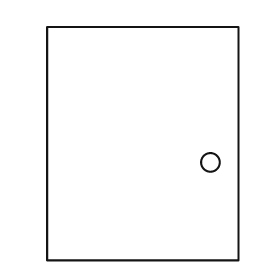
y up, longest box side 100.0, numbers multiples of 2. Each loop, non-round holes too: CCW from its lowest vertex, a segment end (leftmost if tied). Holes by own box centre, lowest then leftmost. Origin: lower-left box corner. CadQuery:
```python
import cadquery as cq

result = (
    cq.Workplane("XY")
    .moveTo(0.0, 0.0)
    .lineTo(82.0, 0.0)
    .lineTo(82.0, 100.0)
    .lineTo(0.0, 100.0)
    .close()
    .moveTo(70.0, 42.0)
    .circle(4.0)
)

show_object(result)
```